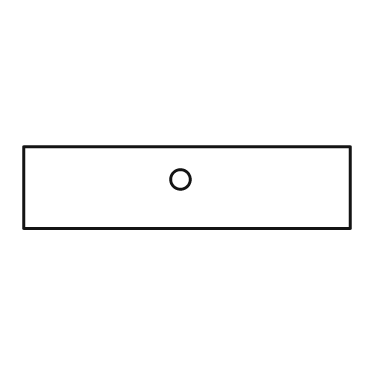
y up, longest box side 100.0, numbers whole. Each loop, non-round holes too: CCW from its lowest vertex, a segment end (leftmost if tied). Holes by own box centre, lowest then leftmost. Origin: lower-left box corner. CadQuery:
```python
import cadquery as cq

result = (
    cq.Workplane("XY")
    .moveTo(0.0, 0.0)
    .lineTo(100.0, 0.0)
    .lineTo(100.0, 25.0)
    .lineTo(0.0, 25.0)
    .close()
    .moveTo(48.0, 15.0)
    .circle(3.0)
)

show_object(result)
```